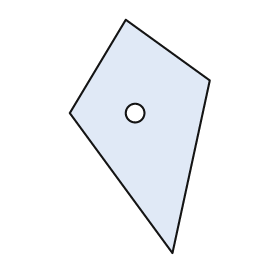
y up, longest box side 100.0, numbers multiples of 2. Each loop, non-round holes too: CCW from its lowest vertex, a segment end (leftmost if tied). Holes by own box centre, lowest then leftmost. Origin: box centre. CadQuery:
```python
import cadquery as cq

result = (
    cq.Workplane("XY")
    .moveTo(14.0, -50.0)
    .lineTo(30.0, 24.0)
    .lineTo(-6.0, 50.0)
    .lineTo(-30.0, 10.0)
    .close()
    .moveTo(-2.0, 10.0)
    .circle(4.0)
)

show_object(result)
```